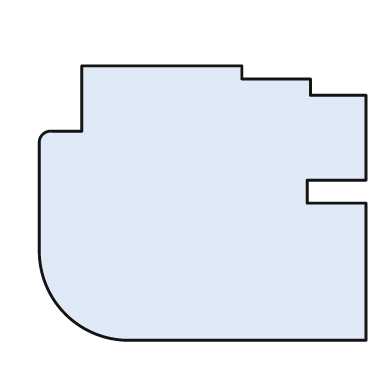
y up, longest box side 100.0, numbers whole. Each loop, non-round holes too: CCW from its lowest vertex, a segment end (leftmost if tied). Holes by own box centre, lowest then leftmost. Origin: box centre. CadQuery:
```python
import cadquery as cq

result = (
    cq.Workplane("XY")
    .moveTo(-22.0, -42.0)
    .lineTo(50.0, -42.0)
    .lineTo(50.0, 0.0)
    .lineTo(32.0, 0.0)
    .lineTo(32.0, 7.0)
    .lineTo(50.0, 7.0)
    .lineTo(50.0, 33.0)
    .lineTo(33.0, 33.0)
    .lineTo(33.0, 38.0)
    .lineTo(12.0, 38.0)
    .lineTo(12.0, 42.0)
    .lineTo(-37.0, 42.0)
    .lineTo(-37.0, 22.0)
    .lineTo(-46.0, 22.0)
    .threePointArc((-49.0, 21.0), (-50.0, 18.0))
    .lineTo(-50.0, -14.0)
    .threePointArc((-42.0, -34.0), (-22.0, -42.0))
    .close()
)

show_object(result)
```